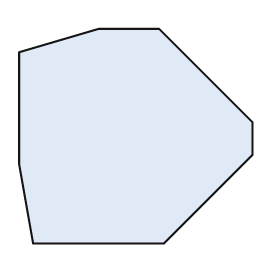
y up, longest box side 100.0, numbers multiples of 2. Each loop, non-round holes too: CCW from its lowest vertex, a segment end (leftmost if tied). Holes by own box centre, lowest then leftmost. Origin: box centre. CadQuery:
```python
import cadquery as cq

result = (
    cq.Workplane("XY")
    .moveTo(-44.0, -46.0)
    .lineTo(12.0, -46.0)
    .lineTo(50.0, -8.0)
    .lineTo(50.0, 6.0)
    .lineTo(10.0, 46.0)
    .lineTo(-16.0, 46.0)
    .lineTo(-50.0, 36.0)
    .lineTo(-50.0, -12.0)
    .close()
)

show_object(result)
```